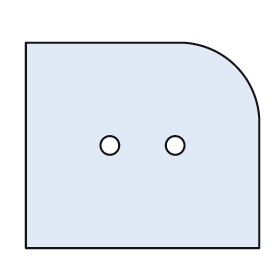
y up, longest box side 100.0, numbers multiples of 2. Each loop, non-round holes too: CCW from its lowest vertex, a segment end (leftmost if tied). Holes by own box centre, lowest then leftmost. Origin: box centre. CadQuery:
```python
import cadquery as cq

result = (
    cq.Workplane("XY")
    .moveTo(-50.0, -44.0)
    .lineTo(50.0, -44.0)
    .lineTo(50.0, 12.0)
    .threePointArc((40.0, 34.0), (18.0, 44.0))
    .lineTo(-50.0, 44.0)
    .close()
    .moveTo(-14.0, 0.0)
    .circle(4.0)
    .moveTo(14.0, 0.0)
    .circle(4.0)
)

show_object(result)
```